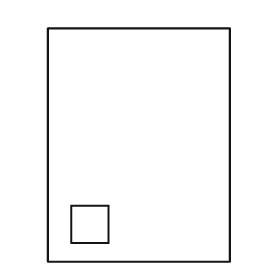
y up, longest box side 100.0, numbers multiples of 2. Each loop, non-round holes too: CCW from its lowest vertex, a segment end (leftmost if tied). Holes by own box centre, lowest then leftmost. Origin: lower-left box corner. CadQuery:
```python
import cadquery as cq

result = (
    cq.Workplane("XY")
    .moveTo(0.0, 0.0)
    .lineTo(78.0, 0.0)
    .lineTo(78.0, 100.0)
    .lineTo(0.0, 100.0)
    .close()
    .moveTo(10.0, 8.0)
    .lineTo(26.0, 8.0)
    .lineTo(26.0, 24.0)
    .lineTo(10.0, 24.0)
    .close()
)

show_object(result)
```